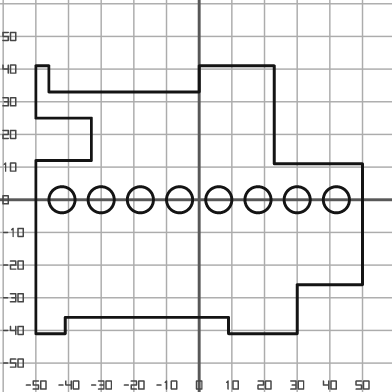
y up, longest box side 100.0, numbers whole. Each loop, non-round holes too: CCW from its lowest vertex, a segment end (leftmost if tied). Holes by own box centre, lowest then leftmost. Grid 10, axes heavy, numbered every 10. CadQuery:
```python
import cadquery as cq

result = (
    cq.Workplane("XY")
    .moveTo(-50.0, -41.0)
    .lineTo(-41.0, -41.0)
    .lineTo(-41.0, -36.0)
    .lineTo(9.0, -36.0)
    .lineTo(9.0, -41.0)
    .lineTo(30.0, -41.0)
    .lineTo(30.0, -26.0)
    .lineTo(50.0, -26.0)
    .lineTo(50.0, 11.0)
    .lineTo(23.0, 11.0)
    .lineTo(23.0, 41.0)
    .lineTo(0.0, 41.0)
    .lineTo(0.0, 33.0)
    .lineTo(-46.0, 33.0)
    .lineTo(-46.0, 41.0)
    .lineTo(-50.0, 41.0)
    .lineTo(-50.0, 25.0)
    .lineTo(-33.0, 25.0)
    .lineTo(-33.0, 12.0)
    .lineTo(-50.0, 12.0)
    .close()
    .moveTo(-42.0, 0.0)
    .circle(4.0)
    .moveTo(-30.0, 0.0)
    .circle(4.0)
    .moveTo(-18.0, 0.0)
    .circle(4.0)
    .moveTo(-6.0, 0.0)
    .circle(4.0)
    .moveTo(6.0, 0.0)
    .circle(4.0)
    .moveTo(18.0, 0.0)
    .circle(4.0)
    .moveTo(30.0, 0.0)
    .circle(4.0)
    .moveTo(42.0, 0.0)
    .circle(4.0)
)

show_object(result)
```